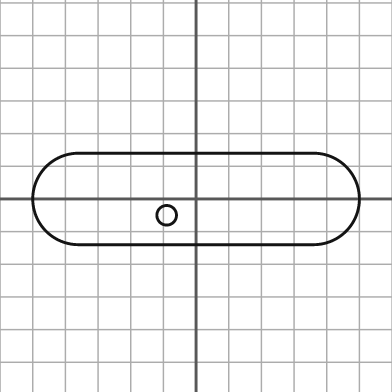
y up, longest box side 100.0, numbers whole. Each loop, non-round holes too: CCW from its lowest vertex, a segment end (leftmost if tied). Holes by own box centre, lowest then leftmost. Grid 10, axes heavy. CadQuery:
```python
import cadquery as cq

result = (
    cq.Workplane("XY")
    .moveTo(-36.0, -14.0)
    .lineTo(36.0, -14.0)
    .threePointArc((50.0, 0.0), (36.0, 14.0))
    .lineTo(-36.0, 14.0)
    .threePointArc((-50.0, 0.0), (-36.0, -14.0))
    .close()
    .moveTo(-9.0, -5.0)
    .circle(3.0)
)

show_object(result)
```